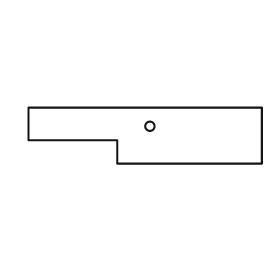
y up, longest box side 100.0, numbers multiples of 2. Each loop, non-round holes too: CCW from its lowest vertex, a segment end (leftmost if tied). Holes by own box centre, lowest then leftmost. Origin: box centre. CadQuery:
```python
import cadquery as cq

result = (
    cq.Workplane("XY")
    .moveTo(-12.0, -12.0)
    .lineTo(50.0, -12.0)
    .lineTo(50.0, 12.0)
    .lineTo(-50.0, 12.0)
    .lineTo(-50.0, -2.0)
    .lineTo(-12.0, -2.0)
    .close()
    .moveTo(2.0, 4.0)
    .circle(2.0)
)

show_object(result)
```